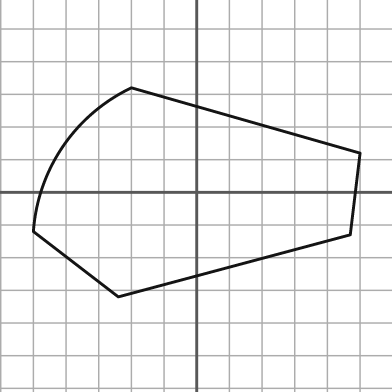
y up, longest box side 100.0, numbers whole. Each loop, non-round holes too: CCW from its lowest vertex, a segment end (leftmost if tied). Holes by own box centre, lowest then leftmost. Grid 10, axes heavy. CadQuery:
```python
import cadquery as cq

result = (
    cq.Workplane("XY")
    .moveTo(-24.0, -32.0)
    .lineTo(47.0, -13.0)
    .lineTo(50.0, 12.0)
    .lineTo(-20.0, 32.0)
    .threePointArc((-41.0, 14.0), (-50.0, -12.0))
    .close()
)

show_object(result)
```